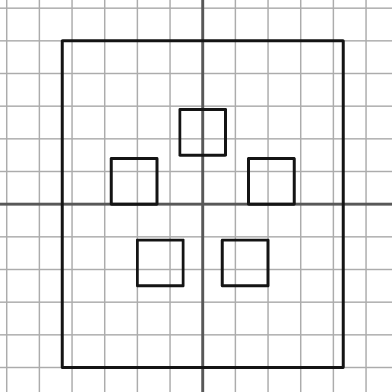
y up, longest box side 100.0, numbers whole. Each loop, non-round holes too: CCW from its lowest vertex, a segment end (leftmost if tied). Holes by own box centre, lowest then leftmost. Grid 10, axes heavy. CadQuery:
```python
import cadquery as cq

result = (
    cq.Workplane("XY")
    .moveTo(-43.0, -50.0)
    .lineTo(43.0, -50.0)
    .lineTo(43.0, 50.0)
    .lineTo(-43.0, 50.0)
    .close()
    .moveTo(-20.0, -25.0)
    .lineTo(-6.0, -25.0)
    .lineTo(-6.0, -11.0)
    .lineTo(-20.0, -11.0)
    .close()
    .moveTo(6.0, -25.0)
    .lineTo(20.0, -25.0)
    .lineTo(20.0, -11.0)
    .lineTo(6.0, -11.0)
    .close()
    .moveTo(-28.0, 0.0)
    .lineTo(-14.0, 0.0)
    .lineTo(-14.0, 14.0)
    .lineTo(-28.0, 14.0)
    .close()
    .moveTo(14.0, 0.0)
    .lineTo(28.0, 0.0)
    .lineTo(28.0, 14.0)
    .lineTo(14.0, 14.0)
    .close()
    .moveTo(-7.0, 15.0)
    .lineTo(7.0, 15.0)
    .lineTo(7.0, 29.0)
    .lineTo(-7.0, 29.0)
    .close()
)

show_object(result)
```